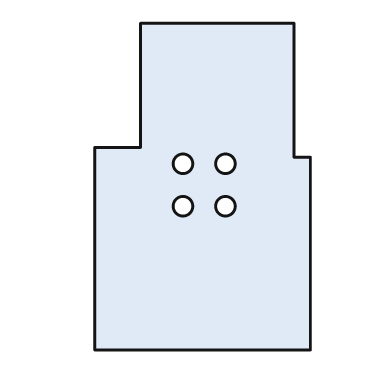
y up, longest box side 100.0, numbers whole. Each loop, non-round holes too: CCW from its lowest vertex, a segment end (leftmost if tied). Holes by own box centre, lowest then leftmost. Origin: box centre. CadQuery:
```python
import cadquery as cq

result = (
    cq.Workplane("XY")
    .moveTo(-33.0, -50.0)
    .lineTo(33.0, -50.0)
    .lineTo(33.0, 9.0)
    .lineTo(28.0, 9.0)
    .lineTo(28.0, 50.0)
    .lineTo(-19.0, 50.0)
    .lineTo(-19.0, 12.0)
    .lineTo(-33.0, 12.0)
    .close()
    .moveTo(-6.0, -6.0)
    .circle(3.0)
    .moveTo(7.0, -6.0)
    .circle(3.0)
    .moveTo(-6.0, 7.0)
    .circle(3.0)
    .moveTo(7.0, 7.0)
    .circle(3.0)
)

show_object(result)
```